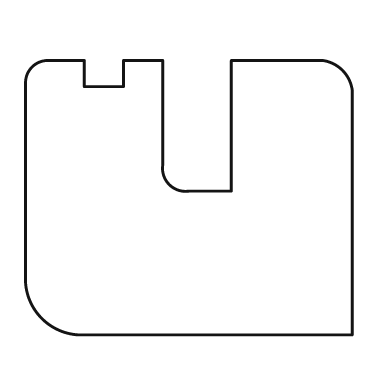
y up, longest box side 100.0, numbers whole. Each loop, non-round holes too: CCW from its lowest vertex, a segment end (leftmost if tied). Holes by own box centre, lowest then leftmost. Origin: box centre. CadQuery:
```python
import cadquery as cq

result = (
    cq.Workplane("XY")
    .moveTo(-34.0, -42.0)
    .lineTo(50.0, -42.0)
    .lineTo(50.0, 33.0)
    .threePointArc((47.0, 39.0), (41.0, 42.0))
    .lineTo(13.0, 42.0)
    .lineTo(13.0, 2.0)
    .lineTo(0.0, 2.0)
    .threePointArc((-6.0, 4.0), (-8.0, 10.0))
    .lineTo(-8.0, 42.0)
    .lineTo(-20.0, 42.0)
    .lineTo(-20.0, 34.0)
    .lineTo(-32.0, 34.0)
    .lineTo(-32.0, 42.0)
    .lineTo(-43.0, 42.0)
    .threePointArc((-48.0, 40.0), (-50.0, 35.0))
    .lineTo(-50.0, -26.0)
    .threePointArc((-45.0, -37.0), (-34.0, -42.0))
    .close()
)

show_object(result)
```